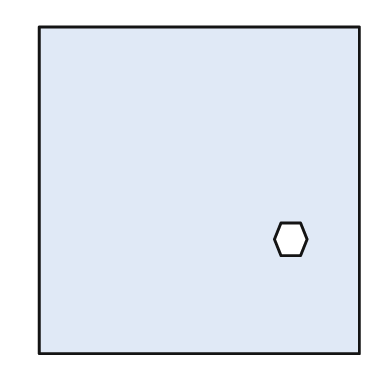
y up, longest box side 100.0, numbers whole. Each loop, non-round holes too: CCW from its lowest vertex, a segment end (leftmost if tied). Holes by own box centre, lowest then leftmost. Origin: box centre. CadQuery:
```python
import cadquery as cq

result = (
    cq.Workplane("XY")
    .moveTo(-49.0, -50.0)
    .lineTo(49.0, -50.0)
    .lineTo(49.0, 50.0)
    .lineTo(-49.0, 50.0)
    .close()
    .moveTo(25.0, -20.0)
    .lineTo(31.0, -20.0)
    .lineTo(33.0, -15.0)
    .lineTo(31.0, -10.0)
    .lineTo(25.0, -10.0)
    .lineTo(23.0, -15.0)
    .close()
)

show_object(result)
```